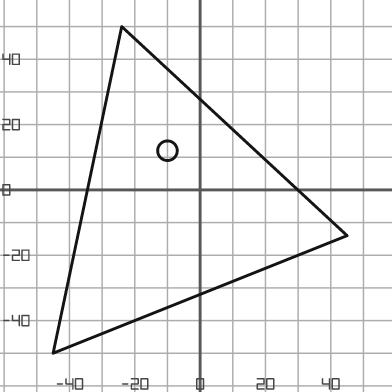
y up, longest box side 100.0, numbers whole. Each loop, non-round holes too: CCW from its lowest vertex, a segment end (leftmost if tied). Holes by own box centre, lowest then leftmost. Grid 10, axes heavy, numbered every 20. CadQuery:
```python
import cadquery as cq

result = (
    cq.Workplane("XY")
    .moveTo(-45.0, -50.0)
    .lineTo(45.0, -14.0)
    .lineTo(-24.0, 50.0)
    .close()
    .moveTo(-10.0, 12.0)
    .circle(3.0)
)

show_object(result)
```